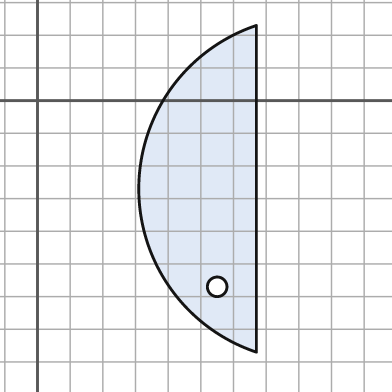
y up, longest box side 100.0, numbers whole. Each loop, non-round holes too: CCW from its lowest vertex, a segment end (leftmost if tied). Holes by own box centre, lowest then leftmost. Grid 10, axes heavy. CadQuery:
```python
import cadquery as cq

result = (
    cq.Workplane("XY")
    .moveTo(67.0, -77.0)
    .lineTo(67.0, 23.0)
    .threePointArc((31.0, -27.0), (67.0, -77.0))
    .close()
    .moveTo(55.0, -57.0)
    .circle(3.0)
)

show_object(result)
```